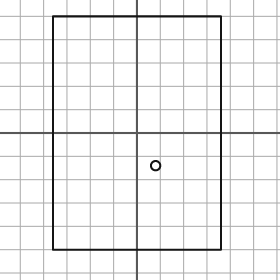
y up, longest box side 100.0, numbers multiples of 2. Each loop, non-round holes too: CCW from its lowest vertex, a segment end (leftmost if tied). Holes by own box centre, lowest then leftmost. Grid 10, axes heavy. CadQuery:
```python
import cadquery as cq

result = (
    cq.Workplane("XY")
    .moveTo(-36.0, -50.0)
    .lineTo(36.0, -50.0)
    .lineTo(36.0, 50.0)
    .lineTo(-36.0, 50.0)
    .close()
    .moveTo(8.0, -14.0)
    .circle(2.0)
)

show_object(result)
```